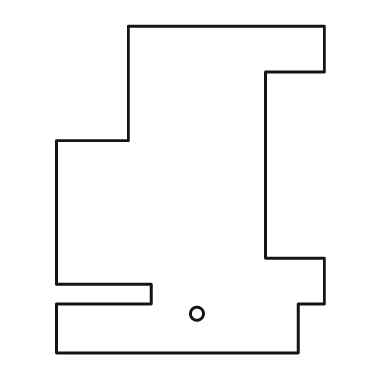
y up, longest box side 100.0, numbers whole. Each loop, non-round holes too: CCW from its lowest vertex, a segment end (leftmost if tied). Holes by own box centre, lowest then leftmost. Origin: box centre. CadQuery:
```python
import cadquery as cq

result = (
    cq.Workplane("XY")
    .moveTo(-41.0, -50.0)
    .lineTo(33.0, -50.0)
    .lineTo(33.0, -35.0)
    .lineTo(41.0, -35.0)
    .lineTo(41.0, -21.0)
    .lineTo(23.0, -21.0)
    .lineTo(23.0, 36.0)
    .lineTo(41.0, 36.0)
    .lineTo(41.0, 50.0)
    .lineTo(-19.0, 50.0)
    .lineTo(-19.0, 15.0)
    .lineTo(-41.0, 15.0)
    .lineTo(-41.0, -29.0)
    .lineTo(-12.0, -29.0)
    .lineTo(-12.0, -35.0)
    .lineTo(-41.0, -35.0)
    .close()
    .moveTo(2.0, -38.0)
    .circle(2.0)
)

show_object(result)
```